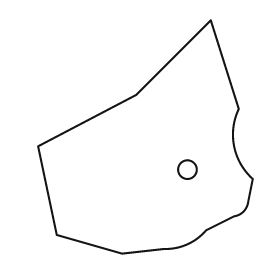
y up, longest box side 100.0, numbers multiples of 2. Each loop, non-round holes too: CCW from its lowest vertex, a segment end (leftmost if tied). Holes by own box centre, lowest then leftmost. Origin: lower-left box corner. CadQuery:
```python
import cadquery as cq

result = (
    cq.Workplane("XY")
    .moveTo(36.0, 0.0)
    .lineTo(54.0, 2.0)
    .threePointArc((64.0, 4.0), (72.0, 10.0))
    .lineTo(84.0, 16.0)
    .threePointArc((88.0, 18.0), (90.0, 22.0))
    .lineTo(92.0, 32.0)
    .threePointArc((84.0, 46.0), (86.0, 62.0))
    .lineTo(74.0, 100.0)
    .lineTo(42.0, 68.0)
    .lineTo(0.0, 46.0)
    .lineTo(8.0, 8.0)
    .close()
    .moveTo(64.0, 36.0)
    .circle(4.0)
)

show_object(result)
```